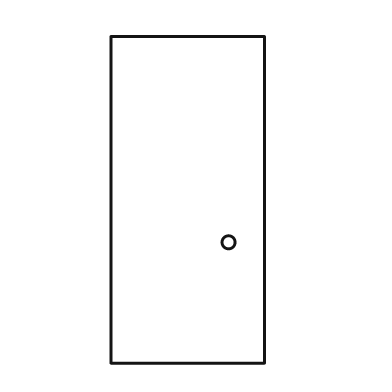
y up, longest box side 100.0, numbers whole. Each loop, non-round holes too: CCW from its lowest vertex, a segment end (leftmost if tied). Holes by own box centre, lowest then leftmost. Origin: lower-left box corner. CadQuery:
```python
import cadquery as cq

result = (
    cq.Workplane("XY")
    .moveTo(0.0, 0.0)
    .lineTo(47.0, 0.0)
    .lineTo(47.0, 100.0)
    .lineTo(0.0, 100.0)
    .close()
    .moveTo(36.0, 37.0)
    .circle(2.0)
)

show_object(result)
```